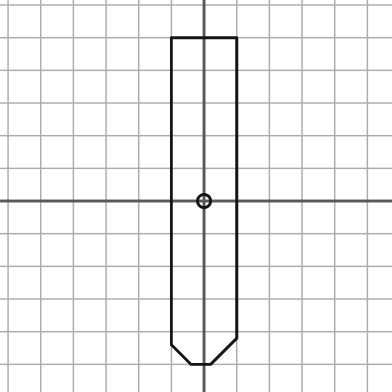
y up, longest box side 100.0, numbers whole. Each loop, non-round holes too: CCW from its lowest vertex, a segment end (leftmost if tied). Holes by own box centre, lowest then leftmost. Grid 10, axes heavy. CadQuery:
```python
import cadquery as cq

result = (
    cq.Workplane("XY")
    .moveTo(-4.0, -50.0)
    .lineTo(2.0, -50.0)
    .lineTo(10.0, -42.0)
    .lineTo(10.0, 50.0)
    .lineTo(-10.0, 50.0)
    .lineTo(-10.0, -44.0)
    .close()
    .moveTo(0.0, 0.0)
    .circle(2.0)
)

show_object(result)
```